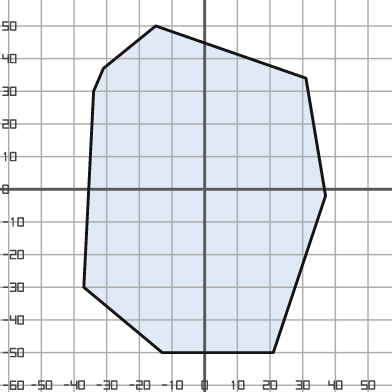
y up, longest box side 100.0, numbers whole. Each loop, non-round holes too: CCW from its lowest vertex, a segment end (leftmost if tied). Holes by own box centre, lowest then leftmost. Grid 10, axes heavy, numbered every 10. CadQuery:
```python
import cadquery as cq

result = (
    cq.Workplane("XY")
    .moveTo(-13.0, -50.0)
    .lineTo(21.0, -50.0)
    .lineTo(37.0, -2.0)
    .lineTo(31.0, 34.0)
    .lineTo(-15.0, 50.0)
    .lineTo(-31.0, 37.0)
    .lineTo(-34.0, 30.0)
    .lineTo(-37.0, -30.0)
    .close()
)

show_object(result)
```